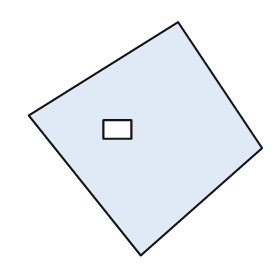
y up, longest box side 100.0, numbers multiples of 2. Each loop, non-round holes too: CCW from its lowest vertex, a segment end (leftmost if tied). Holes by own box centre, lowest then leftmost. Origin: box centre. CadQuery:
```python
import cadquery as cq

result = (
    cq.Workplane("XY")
    .moveTo(-2.0, -50.0)
    .lineTo(50.0, -4.0)
    .lineTo(14.0, 50.0)
    .lineTo(-50.0, 10.0)
    .close()
    .moveTo(-18.0, 0.0)
    .lineTo(-6.0, 0.0)
    .lineTo(-6.0, 8.0)
    .lineTo(-18.0, 8.0)
    .close()
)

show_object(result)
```